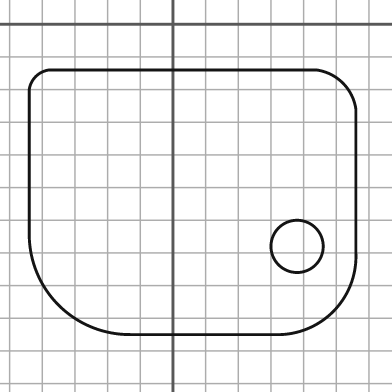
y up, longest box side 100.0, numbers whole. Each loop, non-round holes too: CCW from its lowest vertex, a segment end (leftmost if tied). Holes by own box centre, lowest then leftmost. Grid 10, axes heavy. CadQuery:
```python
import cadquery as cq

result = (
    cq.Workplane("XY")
    .moveTo(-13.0, -95.0)
    .lineTo(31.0, -95.0)
    .threePointArc((49.0, -88.0), (56.0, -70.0))
    .lineTo(56.0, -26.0)
    .threePointArc((52.0, -18.0), (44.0, -14.0))
    .lineTo(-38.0, -14.0)
    .threePointArc((-42.0, -16.0), (-44.0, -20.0))
    .lineTo(-44.0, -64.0)
    .threePointArc((-35.0, -86.0), (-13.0, -95.0))
    .close()
    .moveTo(38.0, -68.0)
    .circle(8.0)
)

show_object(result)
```